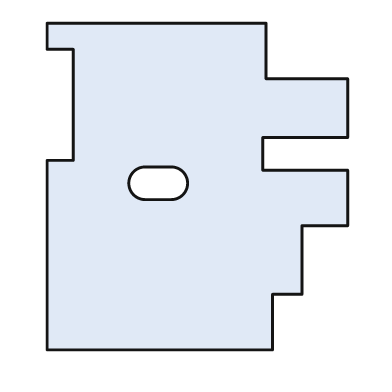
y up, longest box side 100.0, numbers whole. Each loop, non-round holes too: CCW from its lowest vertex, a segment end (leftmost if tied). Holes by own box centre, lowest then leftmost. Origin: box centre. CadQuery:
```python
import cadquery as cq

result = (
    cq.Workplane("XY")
    .moveTo(-46.0, -50.0)
    .lineTo(23.0, -50.0)
    .lineTo(23.0, -33.0)
    .lineTo(32.0, -33.0)
    .lineTo(32.0, -12.0)
    .lineTo(46.0, -12.0)
    .lineTo(46.0, 5.0)
    .lineTo(20.0, 5.0)
    .lineTo(20.0, 15.0)
    .lineTo(46.0, 15.0)
    .lineTo(46.0, 33.0)
    .lineTo(21.0, 33.0)
    .lineTo(21.0, 50.0)
    .lineTo(-46.0, 50.0)
    .lineTo(-46.0, 42.0)
    .lineTo(-38.0, 42.0)
    .lineTo(-38.0, 8.0)
    .lineTo(-46.0, 8.0)
    .close()
    .moveTo(-16.0, -4.0)
    .lineTo(-8.0, -4.0)
    .threePointArc((-3.0, 1.0), (-8.0, 6.0))
    .lineTo(-16.0, 6.0)
    .threePointArc((-21.0, 1.0), (-16.0, -4.0))
    .close()
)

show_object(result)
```